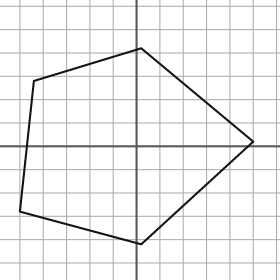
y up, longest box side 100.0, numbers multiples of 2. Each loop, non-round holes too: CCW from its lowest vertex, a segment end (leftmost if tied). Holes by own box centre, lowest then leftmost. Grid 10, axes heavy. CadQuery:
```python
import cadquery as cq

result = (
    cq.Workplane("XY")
    .moveTo(2.0, -42.0)
    .lineTo(50.0, 2.0)
    .lineTo(2.0, 42.0)
    .lineTo(-44.0, 28.0)
    .lineTo(-50.0, -28.0)
    .close()
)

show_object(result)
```